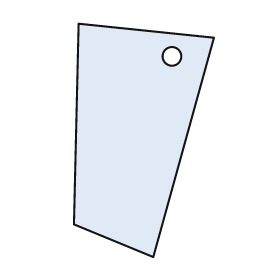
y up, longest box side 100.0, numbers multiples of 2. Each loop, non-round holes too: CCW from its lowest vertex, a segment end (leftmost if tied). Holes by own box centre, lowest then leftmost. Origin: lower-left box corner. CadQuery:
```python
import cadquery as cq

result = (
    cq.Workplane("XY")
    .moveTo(34.0, 0.0)
    .lineTo(60.0, 94.0)
    .lineTo(2.0, 100.0)
    .lineTo(0.0, 14.0)
    .close()
    .moveTo(42.0, 86.0)
    .circle(4.0)
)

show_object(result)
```